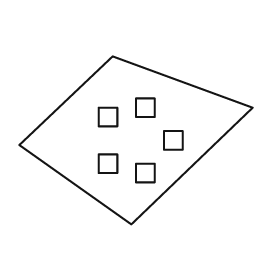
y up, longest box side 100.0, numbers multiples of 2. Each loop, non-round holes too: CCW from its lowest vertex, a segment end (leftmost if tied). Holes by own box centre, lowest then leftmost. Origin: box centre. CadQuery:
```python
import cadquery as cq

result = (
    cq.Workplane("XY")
    .moveTo(-2.0, -36.0)
    .lineTo(50.0, 14.0)
    .lineTo(-10.0, 36.0)
    .lineTo(-50.0, -2.0)
    .close()
    .moveTo(0.0, -18.0)
    .lineTo(8.0, -18.0)
    .lineTo(8.0, -10.0)
    .lineTo(0.0, -10.0)
    .close()
    .moveTo(-16.0, -14.0)
    .lineTo(-8.0, -14.0)
    .lineTo(-8.0, -6.0)
    .lineTo(-16.0, -6.0)
    .close()
    .moveTo(12.0, -4.0)
    .lineTo(20.0, -4.0)
    .lineTo(20.0, 4.0)
    .lineTo(12.0, 4.0)
    .close()
    .moveTo(-16.0, 6.0)
    .lineTo(-8.0, 6.0)
    .lineTo(-8.0, 14.0)
    .lineTo(-16.0, 14.0)
    .close()
    .moveTo(0.0, 10.0)
    .lineTo(8.0, 10.0)
    .lineTo(8.0, 18.0)
    .lineTo(0.0, 18.0)
    .close()
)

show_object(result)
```